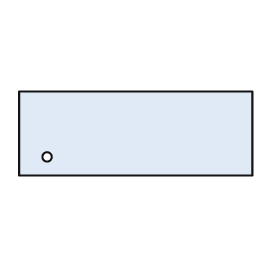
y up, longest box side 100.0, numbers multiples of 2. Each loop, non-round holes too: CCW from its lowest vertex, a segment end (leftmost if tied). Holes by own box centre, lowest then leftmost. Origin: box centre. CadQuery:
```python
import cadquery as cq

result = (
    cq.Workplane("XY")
    .moveTo(-50.0, -18.0)
    .lineTo(50.0, -18.0)
    .lineTo(50.0, 18.0)
    .lineTo(-50.0, 18.0)
    .close()
    .moveTo(-38.0, -10.0)
    .circle(2.0)
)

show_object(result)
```